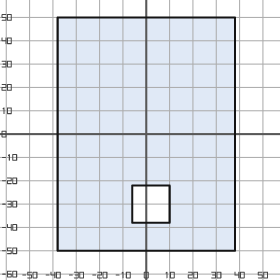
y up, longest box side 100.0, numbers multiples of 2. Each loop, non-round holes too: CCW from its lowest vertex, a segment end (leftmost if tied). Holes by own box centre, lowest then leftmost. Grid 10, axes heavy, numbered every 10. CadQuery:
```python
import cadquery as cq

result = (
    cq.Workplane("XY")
    .moveTo(-38.0, -50.0)
    .lineTo(38.0, -50.0)
    .lineTo(38.0, 50.0)
    .lineTo(-38.0, 50.0)
    .close()
    .moveTo(-6.0, -38.0)
    .lineTo(10.0, -38.0)
    .lineTo(10.0, -22.0)
    .lineTo(-6.0, -22.0)
    .close()
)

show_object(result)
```